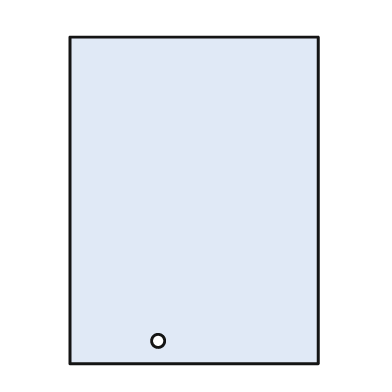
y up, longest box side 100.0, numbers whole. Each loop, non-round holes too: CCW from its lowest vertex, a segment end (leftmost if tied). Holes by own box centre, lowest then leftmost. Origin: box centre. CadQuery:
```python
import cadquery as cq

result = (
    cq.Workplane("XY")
    .moveTo(-38.0, -50.0)
    .lineTo(38.0, -50.0)
    .lineTo(38.0, 50.0)
    .lineTo(-38.0, 50.0)
    .close()
    .moveTo(-11.0, -43.0)
    .circle(2.0)
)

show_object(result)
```